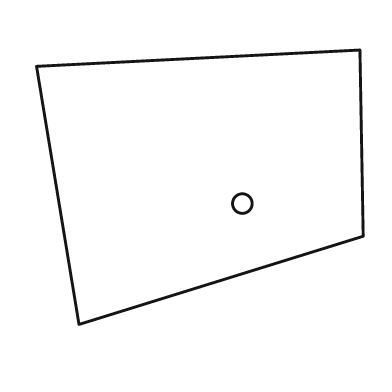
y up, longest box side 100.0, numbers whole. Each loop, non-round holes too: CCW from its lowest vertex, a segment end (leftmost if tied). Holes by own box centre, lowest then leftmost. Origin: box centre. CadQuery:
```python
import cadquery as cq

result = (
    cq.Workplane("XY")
    .moveTo(-37.0, -42.0)
    .lineTo(50.0, -15.0)
    .lineTo(49.0, 42.0)
    .lineTo(-50.0, 37.0)
    .close()
    .moveTo(13.0, -5.0)
    .circle(3.0)
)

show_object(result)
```